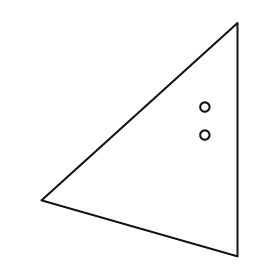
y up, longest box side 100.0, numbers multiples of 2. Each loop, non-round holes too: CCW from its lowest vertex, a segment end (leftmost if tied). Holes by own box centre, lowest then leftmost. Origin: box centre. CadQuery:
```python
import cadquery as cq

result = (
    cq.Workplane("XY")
    .moveTo(42.0, -50.0)
    .lineTo(42.0, 50.0)
    .lineTo(-42.0, -26.0)
    .close()
    .moveTo(28.0, 2.0)
    .circle(2.0)
    .moveTo(28.0, 14.0)
    .circle(2.0)
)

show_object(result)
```